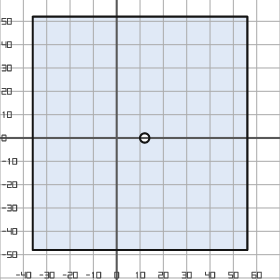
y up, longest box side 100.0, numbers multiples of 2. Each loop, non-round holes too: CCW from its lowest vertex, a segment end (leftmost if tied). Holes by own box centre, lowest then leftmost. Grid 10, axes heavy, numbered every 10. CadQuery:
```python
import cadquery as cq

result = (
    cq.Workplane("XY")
    .moveTo(-36.0, -48.0)
    .lineTo(56.0, -48.0)
    .lineTo(56.0, 52.0)
    .lineTo(-36.0, 52.0)
    .close()
    .moveTo(12.0, 0.0)
    .circle(2.0)
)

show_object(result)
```